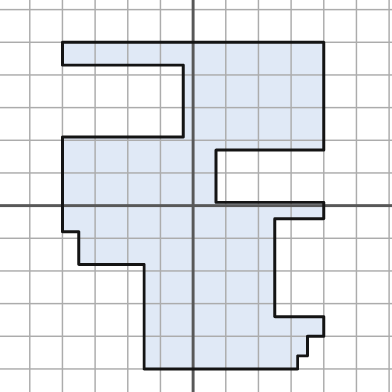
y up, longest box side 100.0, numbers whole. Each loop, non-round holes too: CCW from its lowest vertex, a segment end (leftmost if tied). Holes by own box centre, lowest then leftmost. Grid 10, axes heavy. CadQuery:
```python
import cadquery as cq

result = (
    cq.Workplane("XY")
    .moveTo(-15.0, -50.0)
    .lineTo(32.0, -50.0)
    .lineTo(32.0, -46.0)
    .lineTo(35.0, -46.0)
    .lineTo(35.0, -40.0)
    .lineTo(40.0, -40.0)
    .lineTo(40.0, -34.0)
    .lineTo(25.0, -34.0)
    .lineTo(25.0, -4.0)
    .lineTo(40.0, -4.0)
    .lineTo(40.0, 1.0)
    .lineTo(7.0, 1.0)
    .lineTo(7.0, 17.0)
    .lineTo(40.0, 17.0)
    .lineTo(40.0, 50.0)
    .lineTo(-40.0, 50.0)
    .lineTo(-40.0, 43.0)
    .lineTo(-3.0, 43.0)
    .lineTo(-3.0, 21.0)
    .lineTo(-40.0, 21.0)
    .lineTo(-40.0, -8.0)
    .lineTo(-35.0, -8.0)
    .lineTo(-35.0, -18.0)
    .lineTo(-15.0, -18.0)
    .close()
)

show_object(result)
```